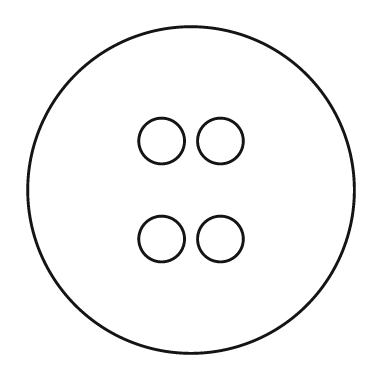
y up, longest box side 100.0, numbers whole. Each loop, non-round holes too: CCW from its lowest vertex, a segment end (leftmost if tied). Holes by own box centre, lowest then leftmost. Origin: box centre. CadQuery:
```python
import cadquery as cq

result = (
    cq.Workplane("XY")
    .moveTo(0.0, 0.0)
    .circle(50.0)
    .moveTo(-9.0, -15.0)
    .circle(7.0)
    .moveTo(9.0, -15.0)
    .circle(7.0)
    .moveTo(-9.0, 15.0)
    .circle(7.0)
    .moveTo(9.0, 15.0)
    .circle(7.0)
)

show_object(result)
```